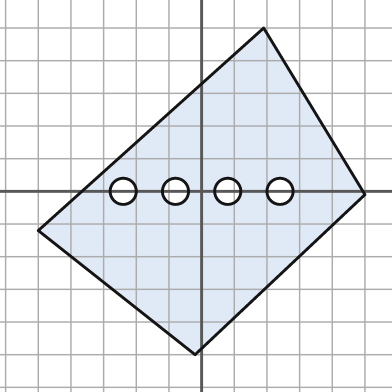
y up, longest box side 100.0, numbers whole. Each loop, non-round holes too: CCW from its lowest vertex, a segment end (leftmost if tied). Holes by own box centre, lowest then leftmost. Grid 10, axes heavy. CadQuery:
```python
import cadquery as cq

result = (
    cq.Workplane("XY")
    .moveTo(-2.0, -50.0)
    .lineTo(50.0, -1.0)
    .lineTo(19.0, 50.0)
    .lineTo(-50.0, -12.0)
    .close()
    .moveTo(-24.0, 0.0)
    .circle(4.0)
    .moveTo(-8.0, 0.0)
    .circle(4.0)
    .moveTo(8.0, 0.0)
    .circle(4.0)
    .moveTo(24.0, 0.0)
    .circle(4.0)
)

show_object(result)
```